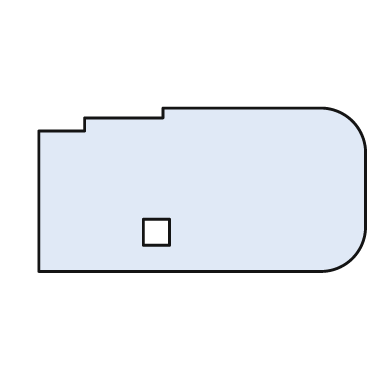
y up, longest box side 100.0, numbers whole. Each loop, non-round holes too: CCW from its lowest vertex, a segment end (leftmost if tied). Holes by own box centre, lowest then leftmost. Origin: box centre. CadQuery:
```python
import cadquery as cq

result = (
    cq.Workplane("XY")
    .moveTo(-50.0, -25.0)
    .lineTo(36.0, -25.0)
    .threePointArc((46.0, -21.0), (50.0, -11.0))
    .lineTo(50.0, 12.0)
    .threePointArc((46.0, 21.0), (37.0, 25.0))
    .lineTo(-12.0, 25.0)
    .lineTo(-12.0, 22.0)
    .lineTo(-36.0, 22.0)
    .lineTo(-36.0, 18.0)
    .lineTo(-50.0, 18.0)
    .close()
    .moveTo(-18.0, -17.0)
    .lineTo(-10.0, -17.0)
    .lineTo(-10.0, -9.0)
    .lineTo(-18.0, -9.0)
    .close()
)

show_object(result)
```